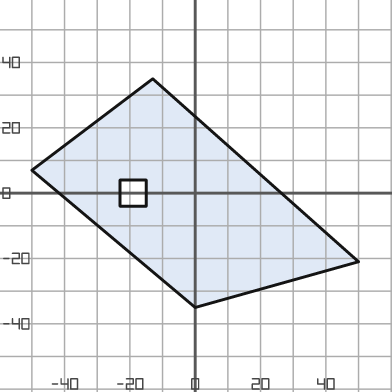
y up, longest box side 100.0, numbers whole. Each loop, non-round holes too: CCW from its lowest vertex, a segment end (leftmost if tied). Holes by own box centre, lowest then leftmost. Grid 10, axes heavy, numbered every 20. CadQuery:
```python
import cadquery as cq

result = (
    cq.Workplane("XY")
    .moveTo(0.0, -35.0)
    .lineTo(50.0, -21.0)
    .lineTo(-13.0, 35.0)
    .lineTo(-50.0, 7.0)
    .close()
    .moveTo(-23.0, -4.0)
    .lineTo(-15.0, -4.0)
    .lineTo(-15.0, 4.0)
    .lineTo(-23.0, 4.0)
    .close()
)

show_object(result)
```